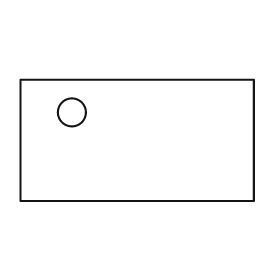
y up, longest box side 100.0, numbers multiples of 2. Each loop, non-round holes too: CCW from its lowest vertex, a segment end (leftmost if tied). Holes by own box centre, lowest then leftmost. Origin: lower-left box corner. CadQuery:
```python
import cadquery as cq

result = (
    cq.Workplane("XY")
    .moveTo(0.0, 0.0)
    .lineTo(100.0, 0.0)
    .lineTo(100.0, 52.0)
    .lineTo(0.0, 52.0)
    .close()
    .moveTo(22.0, 38.0)
    .circle(6.0)
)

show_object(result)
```